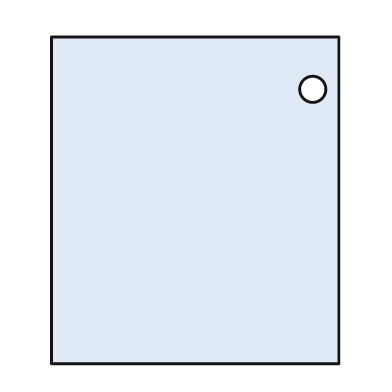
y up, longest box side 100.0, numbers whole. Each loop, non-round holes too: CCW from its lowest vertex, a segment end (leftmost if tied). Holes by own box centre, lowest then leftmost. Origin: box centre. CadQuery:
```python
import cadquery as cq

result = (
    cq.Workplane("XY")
    .moveTo(-44.0, -50.0)
    .lineTo(44.0, -50.0)
    .lineTo(44.0, 50.0)
    .lineTo(-44.0, 50.0)
    .close()
    .moveTo(36.0, 34.0)
    .circle(4.0)
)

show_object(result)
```